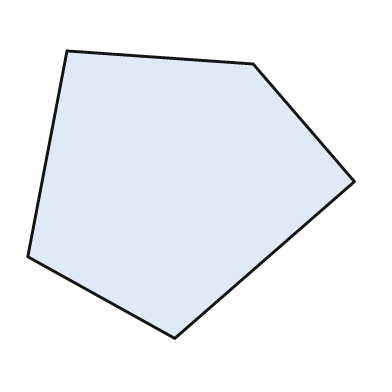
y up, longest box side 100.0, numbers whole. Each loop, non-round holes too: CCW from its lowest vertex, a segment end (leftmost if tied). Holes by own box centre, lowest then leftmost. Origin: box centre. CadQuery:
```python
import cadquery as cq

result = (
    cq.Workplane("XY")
    .moveTo(-5.0, -44.0)
    .lineTo(50.0, 4.0)
    .lineTo(19.0, 40.0)
    .lineTo(-38.0, 44.0)
    .lineTo(-50.0, -19.0)
    .close()
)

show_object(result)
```